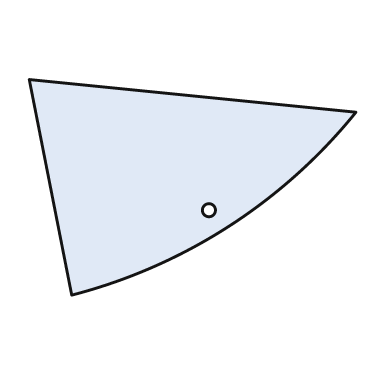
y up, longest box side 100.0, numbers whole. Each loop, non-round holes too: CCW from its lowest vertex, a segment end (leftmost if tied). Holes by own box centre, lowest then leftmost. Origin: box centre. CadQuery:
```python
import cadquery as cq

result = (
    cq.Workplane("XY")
    .moveTo(-37.0, -33.0)
    .threePointArc((11.0, -12.0), (50.0, 23.0))
    .lineTo(-50.0, 33.0)
    .close()
    .moveTo(5.0, -7.0)
    .circle(2.0)
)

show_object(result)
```